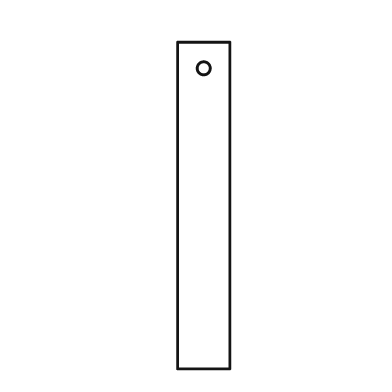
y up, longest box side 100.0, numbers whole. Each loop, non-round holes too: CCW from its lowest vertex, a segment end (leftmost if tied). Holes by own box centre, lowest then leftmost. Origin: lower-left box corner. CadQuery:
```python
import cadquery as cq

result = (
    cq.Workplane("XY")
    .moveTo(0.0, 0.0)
    .lineTo(16.0, 0.0)
    .lineTo(16.0, 100.0)
    .lineTo(0.0, 100.0)
    .close()
    .moveTo(8.0, 92.0)
    .circle(2.0)
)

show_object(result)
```